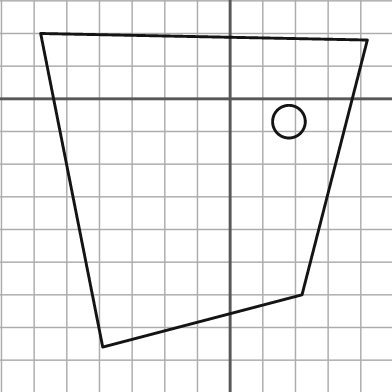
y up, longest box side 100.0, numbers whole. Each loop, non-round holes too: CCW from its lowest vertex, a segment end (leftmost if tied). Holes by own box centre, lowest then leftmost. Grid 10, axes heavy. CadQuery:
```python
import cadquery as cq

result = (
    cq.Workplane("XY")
    .moveTo(-39.0, -76.0)
    .lineTo(22.0, -60.0)
    .lineTo(42.0, 18.0)
    .lineTo(-58.0, 20.0)
    .close()
    .moveTo(18.0, -7.0)
    .circle(5.0)
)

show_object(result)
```